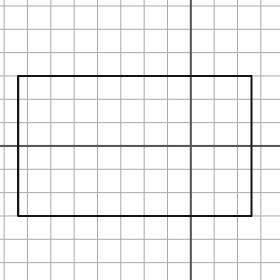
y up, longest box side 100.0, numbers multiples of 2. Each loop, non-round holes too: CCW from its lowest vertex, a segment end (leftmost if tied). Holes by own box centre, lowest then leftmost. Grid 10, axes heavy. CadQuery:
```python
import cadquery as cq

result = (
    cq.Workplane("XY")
    .moveTo(-74.0, -30.0)
    .lineTo(26.0, -30.0)
    .lineTo(26.0, 30.0)
    .lineTo(-74.0, 30.0)
    .close()
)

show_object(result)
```